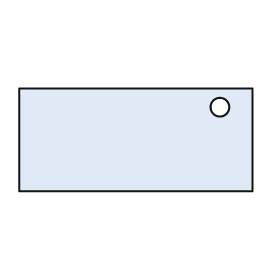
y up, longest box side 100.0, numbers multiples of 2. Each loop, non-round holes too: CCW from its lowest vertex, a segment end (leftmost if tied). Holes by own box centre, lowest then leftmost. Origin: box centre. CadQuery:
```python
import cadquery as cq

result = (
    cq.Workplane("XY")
    .moveTo(-50.0, -22.0)
    .lineTo(50.0, -22.0)
    .lineTo(50.0, 22.0)
    .lineTo(-50.0, 22.0)
    .close()
    .moveTo(36.0, 14.0)
    .circle(4.0)
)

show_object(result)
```